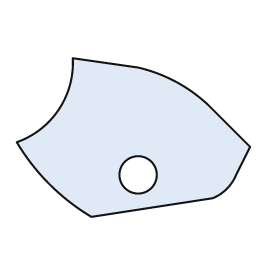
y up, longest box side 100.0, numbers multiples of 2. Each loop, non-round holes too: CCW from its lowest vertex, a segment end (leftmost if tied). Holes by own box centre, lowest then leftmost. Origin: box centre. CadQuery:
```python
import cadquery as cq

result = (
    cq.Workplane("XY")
    .moveTo(-18.0, -34.0)
    .lineTo(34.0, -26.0)
    .threePointArc((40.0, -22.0), (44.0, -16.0))
    .lineTo(50.0, -4.0)
    .lineTo(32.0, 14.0)
    .threePointArc((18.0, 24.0), (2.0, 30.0))
    .lineTo(-26.0, 34.0)
    .threePointArc((-32.0, 12.0), (-50.0, -2.0))
    .threePointArc((-36.0, -20.0), (-18.0, -34.0))
    .close()
    .moveTo(2.0, -16.0)
    .circle(8.0)
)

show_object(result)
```